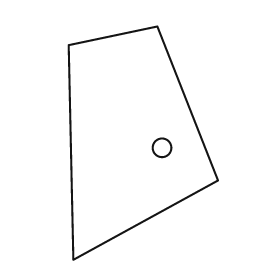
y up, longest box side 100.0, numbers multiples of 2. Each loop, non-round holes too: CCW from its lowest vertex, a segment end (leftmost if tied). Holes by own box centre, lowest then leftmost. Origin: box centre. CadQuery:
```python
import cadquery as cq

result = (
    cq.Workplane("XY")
    .moveTo(-30.0, -50.0)
    .lineTo(32.0, -16.0)
    .lineTo(6.0, 50.0)
    .lineTo(-32.0, 42.0)
    .close()
    .moveTo(8.0, -2.0)
    .circle(4.0)
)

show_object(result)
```